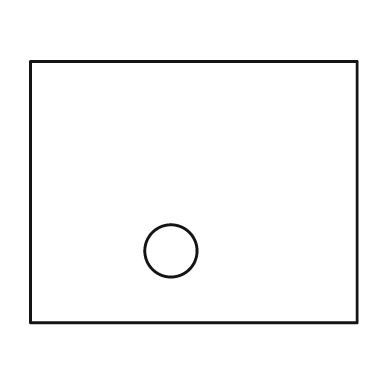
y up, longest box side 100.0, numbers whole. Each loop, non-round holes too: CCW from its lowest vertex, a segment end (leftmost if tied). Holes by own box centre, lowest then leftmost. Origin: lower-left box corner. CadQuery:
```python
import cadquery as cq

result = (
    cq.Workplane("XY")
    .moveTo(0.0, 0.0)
    .lineTo(100.0, 0.0)
    .lineTo(100.0, 80.0)
    .lineTo(0.0, 80.0)
    .close()
    .moveTo(43.0, 22.0)
    .circle(8.0)
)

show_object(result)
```